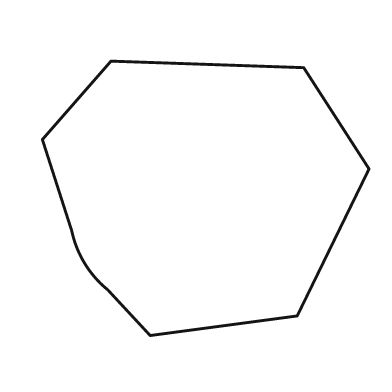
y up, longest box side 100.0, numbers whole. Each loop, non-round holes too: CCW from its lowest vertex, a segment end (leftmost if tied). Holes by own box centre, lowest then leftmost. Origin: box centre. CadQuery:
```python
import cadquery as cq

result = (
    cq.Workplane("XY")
    .moveTo(-17.0, -42.0)
    .lineTo(28.0, -36.0)
    .lineTo(50.0, 9.0)
    .lineTo(30.0, 40.0)
    .lineTo(-29.0, 42.0)
    .lineTo(-50.0, 18.0)
    .lineTo(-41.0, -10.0)
    .threePointArc((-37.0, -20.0), (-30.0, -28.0))
    .close()
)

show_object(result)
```